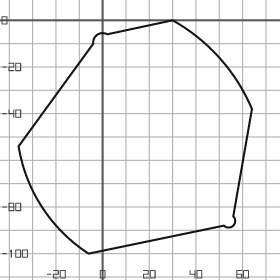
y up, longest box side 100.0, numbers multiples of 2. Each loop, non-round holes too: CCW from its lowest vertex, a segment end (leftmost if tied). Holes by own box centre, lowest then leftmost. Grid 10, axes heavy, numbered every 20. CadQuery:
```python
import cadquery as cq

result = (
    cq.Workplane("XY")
    .moveTo(-6.0, -100.0)
    .lineTo(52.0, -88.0)
    .threePointArc((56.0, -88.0), (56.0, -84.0))
    .lineTo(64.0, -38.0)
    .threePointArc((50.0, -16.0), (30.0, 0.0))
    .lineTo(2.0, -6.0)
    .threePointArc((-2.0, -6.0), (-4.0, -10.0))
    .lineTo(-36.0, -54.0)
    .threePointArc((-26.0, -80.0), (-6.0, -100.0))
    .close()
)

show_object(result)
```